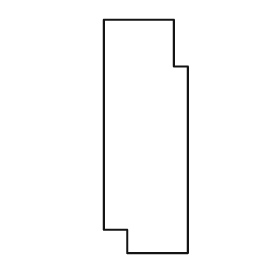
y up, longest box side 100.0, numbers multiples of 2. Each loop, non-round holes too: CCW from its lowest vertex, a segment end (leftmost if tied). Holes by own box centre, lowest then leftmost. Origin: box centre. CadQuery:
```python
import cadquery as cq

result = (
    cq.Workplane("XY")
    .moveTo(-8.0, -50.0)
    .lineTo(18.0, -50.0)
    .lineTo(18.0, 30.0)
    .lineTo(12.0, 30.0)
    .lineTo(12.0, 50.0)
    .lineTo(-18.0, 50.0)
    .lineTo(-18.0, -40.0)
    .lineTo(-8.0, -40.0)
    .close()
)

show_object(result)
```